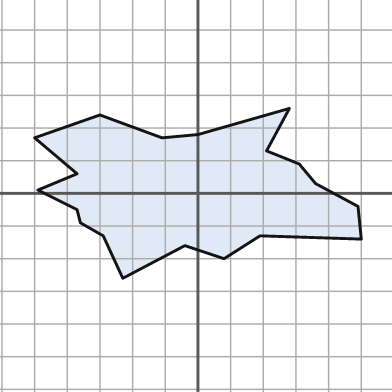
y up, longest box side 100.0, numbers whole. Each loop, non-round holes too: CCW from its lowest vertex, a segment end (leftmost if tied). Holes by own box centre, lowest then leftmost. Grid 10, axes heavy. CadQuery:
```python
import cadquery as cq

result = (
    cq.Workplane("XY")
    .moveTo(-23.0, -26.0)
    .lineTo(-4.0, -16.0)
    .lineTo(8.0, -20.0)
    .lineTo(19.0, -13.0)
    .lineTo(50.0, -14.0)
    .lineTo(49.0, -4.0)
    .lineTo(36.0, 3.0)
    .lineTo(31.0, 9.0)
    .lineTo(21.0, 13.0)
    .lineTo(28.0, 26.0)
    .lineTo(0.0, 18.0)
    .lineTo(-11.0, 17.0)
    .lineTo(-30.0, 24.0)
    .lineTo(-50.0, 17.0)
    .lineTo(-37.0, 6.0)
    .lineTo(-49.0, 1.0)
    .lineTo(-37.0, -5.0)
    .lineTo(-36.0, -9.0)
    .lineTo(-29.0, -13.0)
    .close()
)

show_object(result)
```